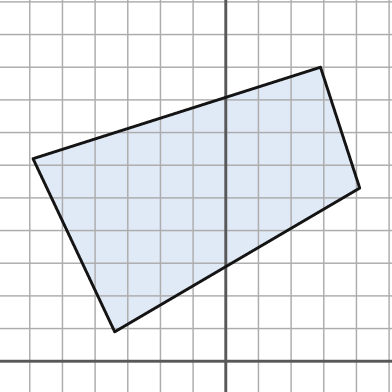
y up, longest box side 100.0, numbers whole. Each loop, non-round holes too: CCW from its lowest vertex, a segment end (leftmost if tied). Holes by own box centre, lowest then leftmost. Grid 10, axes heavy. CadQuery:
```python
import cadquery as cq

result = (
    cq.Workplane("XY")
    .moveTo(-34.0, 9.0)
    .lineTo(41.0, 53.0)
    .lineTo(29.0, 90.0)
    .lineTo(-59.0, 62.0)
    .close()
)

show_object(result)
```